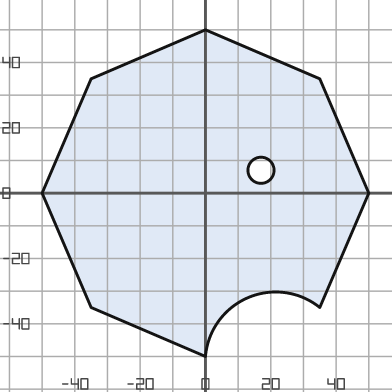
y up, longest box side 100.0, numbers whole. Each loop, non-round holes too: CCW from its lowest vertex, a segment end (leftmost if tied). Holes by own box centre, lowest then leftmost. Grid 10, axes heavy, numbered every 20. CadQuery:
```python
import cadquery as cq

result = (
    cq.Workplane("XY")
    .moveTo(0.0, -50.0)
    .threePointArc((13.0, -32.0), (35.0, -35.0))
    .lineTo(50.0, 0.0)
    .lineTo(35.0, 35.0)
    .lineTo(0.0, 50.0)
    .lineTo(-35.0, 35.0)
    .lineTo(-50.0, 0.0)
    .lineTo(-35.0, -35.0)
    .close()
    .moveTo(17.0, 7.0)
    .circle(4.0)
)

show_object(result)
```